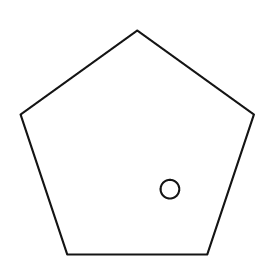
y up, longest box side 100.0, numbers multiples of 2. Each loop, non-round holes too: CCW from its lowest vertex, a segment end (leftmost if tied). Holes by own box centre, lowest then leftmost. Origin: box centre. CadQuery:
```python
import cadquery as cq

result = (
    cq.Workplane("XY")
    .moveTo(-30.0, -48.0)
    .lineTo(30.0, -48.0)
    .lineTo(50.0, 12.0)
    .lineTo(0.0, 48.0)
    .lineTo(-50.0, 12.0)
    .close()
    .moveTo(14.0, -20.0)
    .circle(4.0)
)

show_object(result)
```